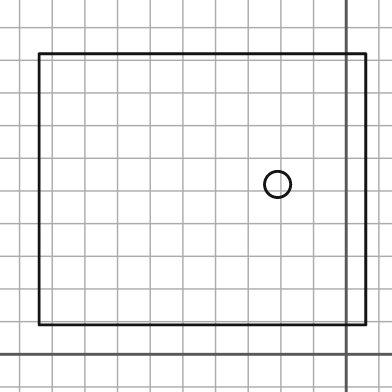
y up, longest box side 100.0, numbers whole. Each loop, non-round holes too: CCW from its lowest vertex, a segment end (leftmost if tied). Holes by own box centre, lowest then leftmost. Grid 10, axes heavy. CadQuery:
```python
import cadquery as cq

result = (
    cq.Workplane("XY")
    .moveTo(-94.0, 9.0)
    .lineTo(6.0, 9.0)
    .lineTo(6.0, 92.0)
    .lineTo(-94.0, 92.0)
    .close()
    .moveTo(-21.0, 52.0)
    .circle(4.0)
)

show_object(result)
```